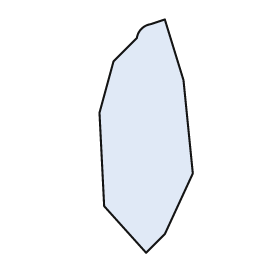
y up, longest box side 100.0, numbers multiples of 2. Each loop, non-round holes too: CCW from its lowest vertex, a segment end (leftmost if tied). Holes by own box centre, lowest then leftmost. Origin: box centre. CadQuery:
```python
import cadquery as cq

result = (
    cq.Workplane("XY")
    .moveTo(0.0, -50.0)
    .lineTo(8.0, -42.0)
    .lineTo(20.0, -16.0)
    .lineTo(16.0, 24.0)
    .lineTo(8.0, 50.0)
    .lineTo(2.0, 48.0)
    .threePointArc((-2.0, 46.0), (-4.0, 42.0))
    .lineTo(-14.0, 32.0)
    .lineTo(-20.0, 10.0)
    .lineTo(-18.0, -30.0)
    .close()
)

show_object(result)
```